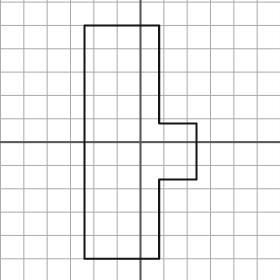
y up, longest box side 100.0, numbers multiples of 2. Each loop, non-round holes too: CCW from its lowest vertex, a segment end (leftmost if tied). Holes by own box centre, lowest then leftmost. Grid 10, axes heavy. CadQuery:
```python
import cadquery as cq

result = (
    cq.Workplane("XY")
    .moveTo(-24.0, -50.0)
    .lineTo(8.0, -50.0)
    .lineTo(8.0, -16.0)
    .lineTo(24.0, -16.0)
    .lineTo(24.0, 8.0)
    .lineTo(8.0, 8.0)
    .lineTo(8.0, 50.0)
    .lineTo(-24.0, 50.0)
    .close()
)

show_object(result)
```